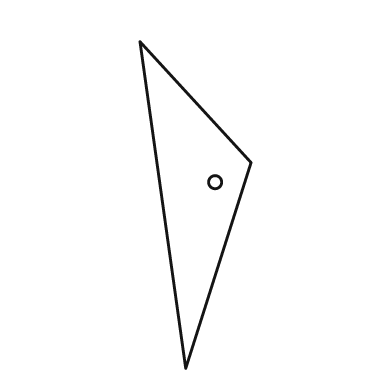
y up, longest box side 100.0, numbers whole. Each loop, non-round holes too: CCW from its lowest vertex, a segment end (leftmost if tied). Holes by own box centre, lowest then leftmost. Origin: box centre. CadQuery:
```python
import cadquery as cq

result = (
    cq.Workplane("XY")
    .moveTo(-3.0, -50.0)
    .lineTo(17.0, 13.0)
    .lineTo(-17.0, 50.0)
    .close()
    .moveTo(6.0, 7.0)
    .circle(2.0)
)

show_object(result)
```